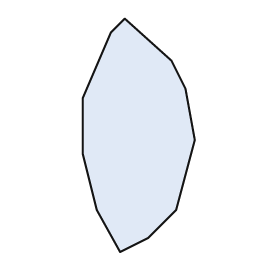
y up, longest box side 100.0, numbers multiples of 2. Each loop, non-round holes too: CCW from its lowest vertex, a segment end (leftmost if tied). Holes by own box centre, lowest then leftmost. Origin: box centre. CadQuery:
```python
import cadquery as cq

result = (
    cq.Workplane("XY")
    .moveTo(-8.0, -50.0)
    .lineTo(4.0, -44.0)
    .lineTo(16.0, -32.0)
    .lineTo(24.0, -2.0)
    .lineTo(20.0, 20.0)
    .lineTo(14.0, 32.0)
    .lineTo(-6.0, 50.0)
    .lineTo(-12.0, 44.0)
    .lineTo(-24.0, 16.0)
    .lineTo(-24.0, -8.0)
    .lineTo(-18.0, -32.0)
    .close()
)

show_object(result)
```